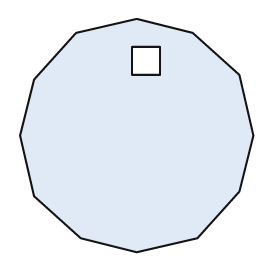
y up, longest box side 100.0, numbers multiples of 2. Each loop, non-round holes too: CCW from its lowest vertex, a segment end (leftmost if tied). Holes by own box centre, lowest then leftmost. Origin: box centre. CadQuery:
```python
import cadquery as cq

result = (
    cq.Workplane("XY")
    .moveTo(0.0, -50.0)
    .lineTo(26.0, -44.0)
    .lineTo(44.0, -24.0)
    .lineTo(50.0, 0.0)
    .lineTo(44.0, 26.0)
    .lineTo(24.0, 44.0)
    .lineTo(0.0, 50.0)
    .lineTo(-26.0, 44.0)
    .lineTo(-44.0, 24.0)
    .lineTo(-50.0, 0.0)
    .lineTo(-44.0, -26.0)
    .lineTo(-24.0, -44.0)
    .close()
    .moveTo(-2.0, 26.0)
    .lineTo(10.0, 26.0)
    .lineTo(10.0, 38.0)
    .lineTo(-2.0, 38.0)
    .close()
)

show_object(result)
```